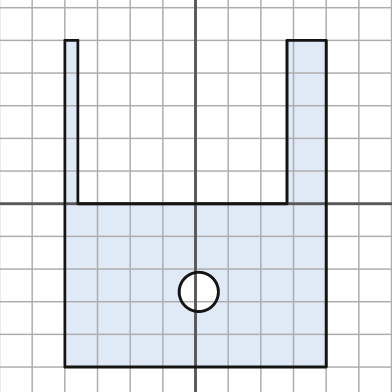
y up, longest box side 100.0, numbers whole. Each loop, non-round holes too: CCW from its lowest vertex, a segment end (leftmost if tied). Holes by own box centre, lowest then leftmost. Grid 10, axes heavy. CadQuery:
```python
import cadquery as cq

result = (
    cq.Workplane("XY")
    .moveTo(-40.0, -50.0)
    .lineTo(40.0, -50.0)
    .lineTo(40.0, 50.0)
    .lineTo(28.0, 50.0)
    .lineTo(28.0, 0.0)
    .lineTo(-36.0, 0.0)
    .lineTo(-36.0, 50.0)
    .lineTo(-40.0, 50.0)
    .close()
    .moveTo(1.0, -27.0)
    .circle(6.0)
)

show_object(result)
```